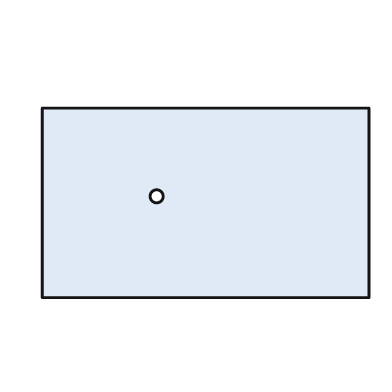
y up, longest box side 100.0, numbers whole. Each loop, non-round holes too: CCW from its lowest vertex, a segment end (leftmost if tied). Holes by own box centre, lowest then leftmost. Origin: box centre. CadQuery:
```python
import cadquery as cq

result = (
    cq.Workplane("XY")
    .moveTo(-50.0, -29.0)
    .lineTo(50.0, -29.0)
    .lineTo(50.0, 29.0)
    .lineTo(-50.0, 29.0)
    .close()
    .moveTo(-15.0, 2.0)
    .circle(2.0)
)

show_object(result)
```